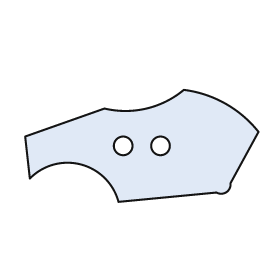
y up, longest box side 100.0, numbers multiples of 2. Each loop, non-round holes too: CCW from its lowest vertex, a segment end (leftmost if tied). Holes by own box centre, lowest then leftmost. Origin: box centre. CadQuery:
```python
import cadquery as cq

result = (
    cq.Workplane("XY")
    .moveTo(-10.0, -24.0)
    .lineTo(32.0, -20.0)
    .threePointArc((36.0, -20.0), (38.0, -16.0))
    .lineTo(50.0, 6.0)
    .threePointArc((36.0, 18.0), (18.0, 24.0))
    .threePointArc((2.0, 16.0), (-16.0, 16.0))
    .lineTo(-50.0, 4.0)
    .lineTo(-48.0, -14.0)
    .threePointArc((-26.0, -8.0), (-10.0, -24.0))
    .close()
    .moveTo(-8.0, 0.0)
    .circle(4.0)
    .moveTo(8.0, 0.0)
    .circle(4.0)
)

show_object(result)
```